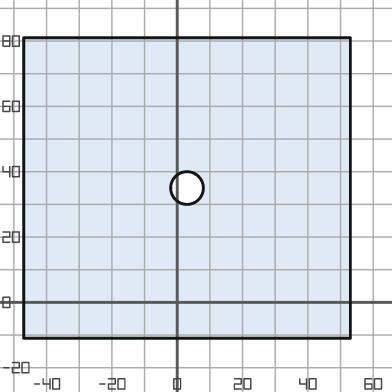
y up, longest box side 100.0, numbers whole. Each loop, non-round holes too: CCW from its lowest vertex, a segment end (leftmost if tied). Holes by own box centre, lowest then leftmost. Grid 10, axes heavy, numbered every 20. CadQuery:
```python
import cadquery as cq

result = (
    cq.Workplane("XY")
    .moveTo(-47.0, -11.0)
    .lineTo(53.0, -11.0)
    .lineTo(53.0, 81.0)
    .lineTo(-47.0, 81.0)
    .close()
    .moveTo(3.0, 35.0)
    .circle(5.0)
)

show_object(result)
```